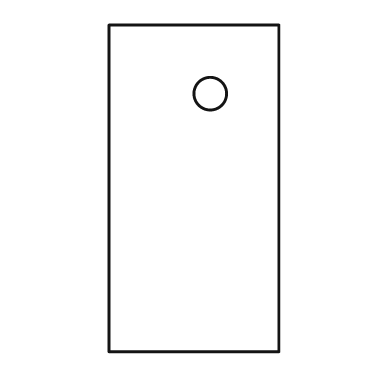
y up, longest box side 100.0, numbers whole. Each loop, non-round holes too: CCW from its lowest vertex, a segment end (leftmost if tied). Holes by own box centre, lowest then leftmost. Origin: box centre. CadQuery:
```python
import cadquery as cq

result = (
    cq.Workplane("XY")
    .moveTo(-26.0, -50.0)
    .lineTo(26.0, -50.0)
    .lineTo(26.0, 50.0)
    .lineTo(-26.0, 50.0)
    .close()
    .moveTo(5.0, 29.0)
    .circle(5.0)
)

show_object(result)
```